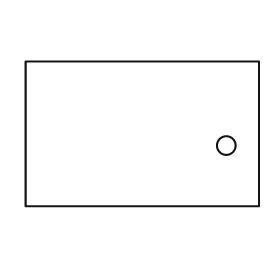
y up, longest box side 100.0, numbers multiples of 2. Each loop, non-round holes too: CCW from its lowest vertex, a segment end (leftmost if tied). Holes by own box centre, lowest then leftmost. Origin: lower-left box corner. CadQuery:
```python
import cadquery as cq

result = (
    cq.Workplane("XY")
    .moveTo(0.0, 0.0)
    .lineTo(100.0, 0.0)
    .lineTo(100.0, 62.0)
    .lineTo(0.0, 62.0)
    .close()
    .moveTo(86.0, 26.0)
    .circle(4.0)
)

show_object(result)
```